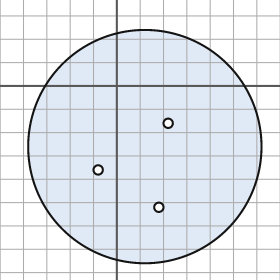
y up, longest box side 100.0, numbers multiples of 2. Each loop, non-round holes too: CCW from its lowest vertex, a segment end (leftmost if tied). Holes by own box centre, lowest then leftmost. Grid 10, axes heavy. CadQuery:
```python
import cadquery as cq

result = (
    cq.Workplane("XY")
    .moveTo(12.0, -26.0)
    .circle(50.0)
    .moveTo(18.0, -52.0)
    .circle(2.0)
    .moveTo(-8.0, -36.0)
    .circle(2.0)
    .moveTo(22.0, -16.0)
    .circle(2.0)
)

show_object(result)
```